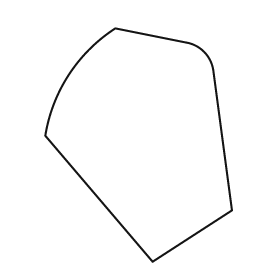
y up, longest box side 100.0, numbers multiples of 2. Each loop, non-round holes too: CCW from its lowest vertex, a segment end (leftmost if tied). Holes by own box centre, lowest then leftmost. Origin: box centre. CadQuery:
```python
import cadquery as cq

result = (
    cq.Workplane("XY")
    .moveTo(6.0, -50.0)
    .lineTo(40.0, -28.0)
    .lineTo(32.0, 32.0)
    .threePointArc((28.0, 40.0), (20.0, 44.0))
    .lineTo(-10.0, 50.0)
    .threePointArc((-30.0, 30.0), (-40.0, 4.0))
    .close()
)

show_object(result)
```